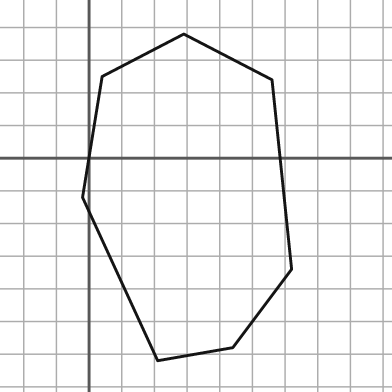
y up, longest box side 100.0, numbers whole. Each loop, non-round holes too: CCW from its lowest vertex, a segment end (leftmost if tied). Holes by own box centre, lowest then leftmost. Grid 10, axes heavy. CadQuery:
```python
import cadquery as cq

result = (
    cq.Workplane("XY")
    .moveTo(21.0, -62.0)
    .lineTo(44.0, -58.0)
    .lineTo(62.0, -34.0)
    .lineTo(56.0, 24.0)
    .lineTo(29.0, 38.0)
    .lineTo(4.0, 25.0)
    .lineTo(-2.0, -12.0)
    .close()
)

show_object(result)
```